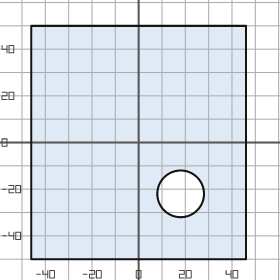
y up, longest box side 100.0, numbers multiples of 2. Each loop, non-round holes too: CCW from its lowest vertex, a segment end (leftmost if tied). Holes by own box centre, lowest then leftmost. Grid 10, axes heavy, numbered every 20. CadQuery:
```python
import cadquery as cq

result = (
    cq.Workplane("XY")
    .moveTo(-46.0, -50.0)
    .lineTo(46.0, -50.0)
    .lineTo(46.0, 50.0)
    .lineTo(-46.0, 50.0)
    .close()
    .moveTo(18.0, -22.0)
    .circle(10.0)
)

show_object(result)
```